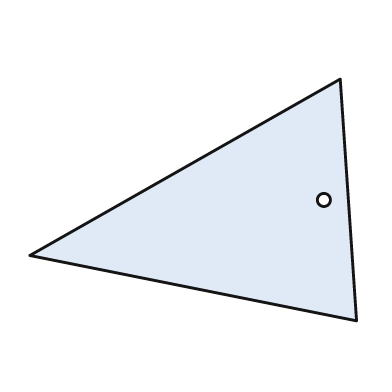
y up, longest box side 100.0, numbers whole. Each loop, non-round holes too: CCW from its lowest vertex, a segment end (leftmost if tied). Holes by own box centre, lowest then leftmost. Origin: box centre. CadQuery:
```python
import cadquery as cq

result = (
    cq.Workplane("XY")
    .moveTo(50.0, -37.0)
    .lineTo(45.0, 37.0)
    .lineTo(-50.0, -17.0)
    .close()
    .moveTo(40.0, 0.0)
    .circle(2.0)
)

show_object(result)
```